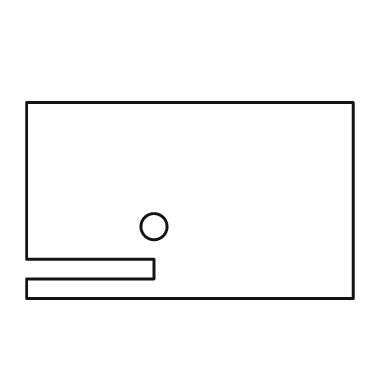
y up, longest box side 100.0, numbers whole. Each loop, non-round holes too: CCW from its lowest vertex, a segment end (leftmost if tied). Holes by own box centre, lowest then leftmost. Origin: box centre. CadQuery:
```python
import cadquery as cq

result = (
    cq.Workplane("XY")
    .moveTo(-50.0, -30.0)
    .lineTo(50.0, -30.0)
    .lineTo(50.0, 30.0)
    .lineTo(-50.0, 30.0)
    .lineTo(-50.0, -18.0)
    .lineTo(-11.0, -18.0)
    .lineTo(-11.0, -24.0)
    .lineTo(-50.0, -24.0)
    .close()
    .moveTo(-11.0, -8.0)
    .circle(4.0)
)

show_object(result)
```